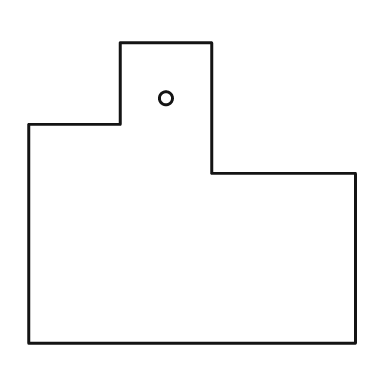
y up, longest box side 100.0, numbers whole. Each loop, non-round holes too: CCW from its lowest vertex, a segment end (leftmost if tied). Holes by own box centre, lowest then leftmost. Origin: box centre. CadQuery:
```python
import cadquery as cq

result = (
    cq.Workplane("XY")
    .moveTo(-50.0, -46.0)
    .lineTo(50.0, -46.0)
    .lineTo(50.0, 6.0)
    .lineTo(6.0, 6.0)
    .lineTo(6.0, 46.0)
    .lineTo(-22.0, 46.0)
    .lineTo(-22.0, 21.0)
    .lineTo(-50.0, 21.0)
    .close()
    .moveTo(-8.0, 29.0)
    .circle(2.0)
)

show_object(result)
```